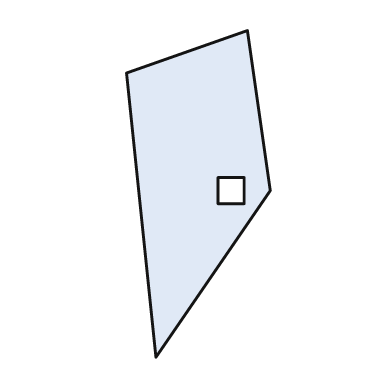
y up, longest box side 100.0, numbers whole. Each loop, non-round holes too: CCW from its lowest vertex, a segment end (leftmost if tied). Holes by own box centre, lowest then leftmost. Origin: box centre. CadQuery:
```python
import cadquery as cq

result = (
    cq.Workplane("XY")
    .moveTo(-13.0, -50.0)
    .lineTo(22.0, 1.0)
    .lineTo(15.0, 50.0)
    .lineTo(-22.0, 37.0)
    .close()
    .moveTo(6.0, -3.0)
    .lineTo(14.0, -3.0)
    .lineTo(14.0, 5.0)
    .lineTo(6.0, 5.0)
    .close()
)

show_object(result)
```